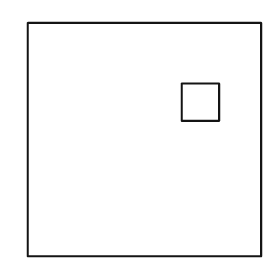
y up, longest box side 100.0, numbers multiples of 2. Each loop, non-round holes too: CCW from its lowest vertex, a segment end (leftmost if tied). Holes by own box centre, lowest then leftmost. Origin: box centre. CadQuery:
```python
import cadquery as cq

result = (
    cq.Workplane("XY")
    .moveTo(-50.0, -50.0)
    .lineTo(50.0, -50.0)
    .lineTo(50.0, 50.0)
    .lineTo(-50.0, 50.0)
    .close()
    .moveTo(16.0, 8.0)
    .lineTo(32.0, 8.0)
    .lineTo(32.0, 24.0)
    .lineTo(16.0, 24.0)
    .close()
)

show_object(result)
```